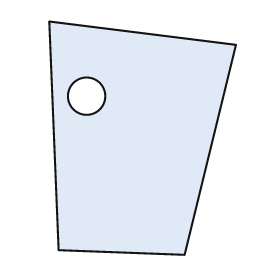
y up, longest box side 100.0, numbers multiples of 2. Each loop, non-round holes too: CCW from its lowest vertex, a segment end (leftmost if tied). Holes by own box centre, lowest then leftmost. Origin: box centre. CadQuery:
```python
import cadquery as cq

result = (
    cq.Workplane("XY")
    .moveTo(18.0, -50.0)
    .lineTo(40.0, 40.0)
    .lineTo(-40.0, 50.0)
    .lineTo(-36.0, -48.0)
    .close()
    .moveTo(-24.0, 18.0)
    .circle(8.0)
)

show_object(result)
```